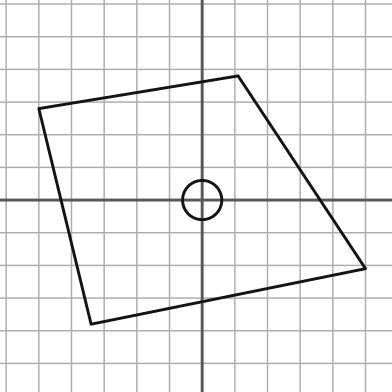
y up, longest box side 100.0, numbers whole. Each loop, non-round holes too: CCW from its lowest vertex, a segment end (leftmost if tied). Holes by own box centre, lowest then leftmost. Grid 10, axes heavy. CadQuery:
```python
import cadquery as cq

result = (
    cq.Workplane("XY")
    .moveTo(-34.0, -38.0)
    .lineTo(50.0, -21.0)
    .lineTo(11.0, 38.0)
    .lineTo(-50.0, 28.0)
    .close()
    .moveTo(0.0, 0.0)
    .circle(6.0)
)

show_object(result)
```